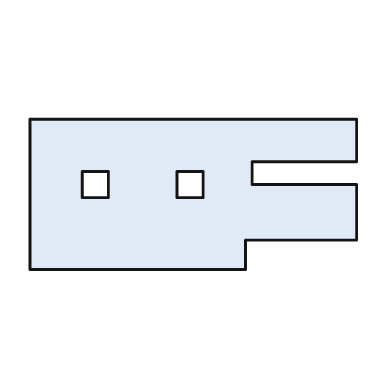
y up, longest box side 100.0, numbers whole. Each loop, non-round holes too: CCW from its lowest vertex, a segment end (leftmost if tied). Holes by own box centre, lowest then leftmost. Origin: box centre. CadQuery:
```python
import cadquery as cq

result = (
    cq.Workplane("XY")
    .moveTo(-50.0, -23.0)
    .lineTo(16.0, -23.0)
    .lineTo(16.0, -14.0)
    .lineTo(50.0, -14.0)
    .lineTo(50.0, 3.0)
    .lineTo(18.0, 3.0)
    .lineTo(18.0, 10.0)
    .lineTo(50.0, 10.0)
    .lineTo(50.0, 23.0)
    .lineTo(-50.0, 23.0)
    .close()
    .moveTo(-34.0, -1.0)
    .lineTo(-26.0, -1.0)
    .lineTo(-26.0, 7.0)
    .lineTo(-34.0, 7.0)
    .close()
    .moveTo(-5.0, -1.0)
    .lineTo(3.0, -1.0)
    .lineTo(3.0, 7.0)
    .lineTo(-5.0, 7.0)
    .close()
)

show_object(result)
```